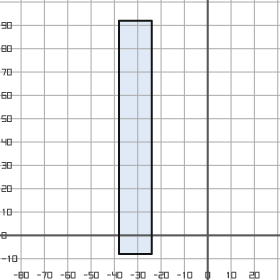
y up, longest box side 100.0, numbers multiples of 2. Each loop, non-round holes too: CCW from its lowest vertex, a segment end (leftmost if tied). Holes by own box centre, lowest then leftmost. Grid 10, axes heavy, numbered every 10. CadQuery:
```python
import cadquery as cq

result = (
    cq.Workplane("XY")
    .moveTo(-38.0, -8.0)
    .lineTo(-24.0, -8.0)
    .lineTo(-24.0, 92.0)
    .lineTo(-38.0, 92.0)
    .close()
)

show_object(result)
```